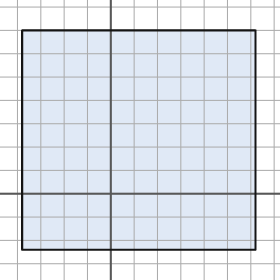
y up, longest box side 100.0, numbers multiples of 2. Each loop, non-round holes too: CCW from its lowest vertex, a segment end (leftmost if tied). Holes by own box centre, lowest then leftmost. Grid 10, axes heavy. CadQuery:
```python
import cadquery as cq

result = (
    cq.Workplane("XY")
    .moveTo(-38.0, -24.0)
    .lineTo(62.0, -24.0)
    .lineTo(62.0, 70.0)
    .lineTo(-38.0, 70.0)
    .close()
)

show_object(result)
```